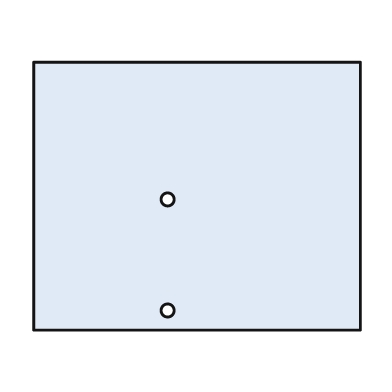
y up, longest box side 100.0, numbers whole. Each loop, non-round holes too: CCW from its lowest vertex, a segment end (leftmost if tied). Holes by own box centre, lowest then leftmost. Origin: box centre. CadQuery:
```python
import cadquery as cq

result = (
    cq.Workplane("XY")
    .moveTo(-50.0, -41.0)
    .lineTo(50.0, -41.0)
    .lineTo(50.0, 41.0)
    .lineTo(-50.0, 41.0)
    .close()
    .moveTo(-9.0, -35.0)
    .circle(2.0)
    .moveTo(-9.0, -1.0)
    .circle(2.0)
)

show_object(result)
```